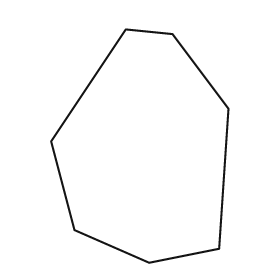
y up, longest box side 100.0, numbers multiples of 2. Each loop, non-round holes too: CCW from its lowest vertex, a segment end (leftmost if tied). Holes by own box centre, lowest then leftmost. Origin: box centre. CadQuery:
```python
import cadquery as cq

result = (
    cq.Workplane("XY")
    .moveTo(4.0, -50.0)
    .lineTo(34.0, -44.0)
    .lineTo(38.0, 16.0)
    .lineTo(14.0, 48.0)
    .lineTo(-6.0, 50.0)
    .lineTo(-38.0, 2.0)
    .lineTo(-28.0, -36.0)
    .close()
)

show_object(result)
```